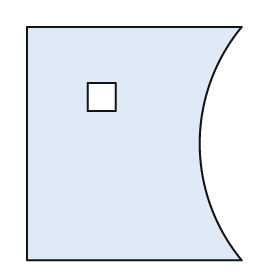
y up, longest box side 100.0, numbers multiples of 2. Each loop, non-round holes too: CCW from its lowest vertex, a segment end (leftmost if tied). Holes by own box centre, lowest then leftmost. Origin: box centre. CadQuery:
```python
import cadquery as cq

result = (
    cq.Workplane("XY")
    .moveTo(-46.0, -50.0)
    .lineTo(46.0, -50.0)
    .threePointArc((28.0, 0.0), (46.0, 50.0))
    .lineTo(-46.0, 50.0)
    .close()
    .moveTo(-20.0, 14.0)
    .lineTo(-8.0, 14.0)
    .lineTo(-8.0, 26.0)
    .lineTo(-20.0, 26.0)
    .close()
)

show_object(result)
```